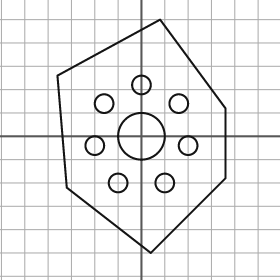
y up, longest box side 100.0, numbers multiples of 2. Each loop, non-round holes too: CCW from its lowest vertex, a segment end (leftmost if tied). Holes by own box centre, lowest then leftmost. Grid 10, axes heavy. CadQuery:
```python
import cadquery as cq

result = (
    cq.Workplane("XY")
    .moveTo(4.0, -50.0)
    .lineTo(36.0, -18.0)
    .lineTo(36.0, 12.0)
    .lineTo(8.0, 50.0)
    .lineTo(-36.0, 26.0)
    .lineTo(-32.0, -22.0)
    .close()
    .moveTo(-10.0, -20.0)
    .circle(4.0)
    .moveTo(10.0, -20.0)
    .circle(4.0)
    .moveTo(-20.0, -4.0)
    .circle(4.0)
    .moveTo(20.0, -4.0)
    .circle(4.0)
    .moveTo(0.0, 0.0)
    .circle(10.0)
    .moveTo(-16.0, 14.0)
    .circle(4.0)
    .moveTo(16.0, 14.0)
    .circle(4.0)
    .moveTo(0.0, 22.0)
    .circle(4.0)
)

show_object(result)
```